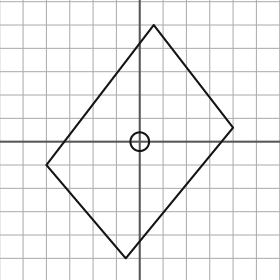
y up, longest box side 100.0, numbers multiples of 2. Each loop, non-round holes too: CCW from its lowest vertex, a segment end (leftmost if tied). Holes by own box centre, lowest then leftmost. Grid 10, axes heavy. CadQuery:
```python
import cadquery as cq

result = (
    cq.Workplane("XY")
    .moveTo(-6.0, -50.0)
    .lineTo(40.0, 6.0)
    .lineTo(6.0, 50.0)
    .lineTo(-40.0, -10.0)
    .close()
    .moveTo(0.0, 0.0)
    .circle(4.0)
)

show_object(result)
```